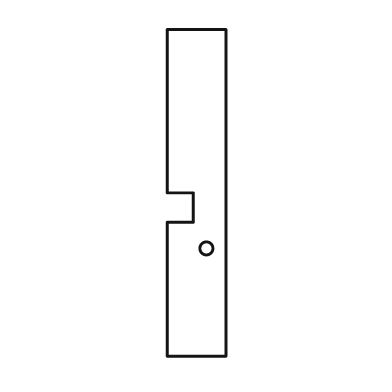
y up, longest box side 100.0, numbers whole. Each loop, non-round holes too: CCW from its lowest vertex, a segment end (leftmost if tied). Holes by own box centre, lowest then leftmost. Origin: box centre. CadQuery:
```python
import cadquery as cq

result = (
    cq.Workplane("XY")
    .moveTo(-9.0, -50.0)
    .lineTo(9.0, -50.0)
    .lineTo(9.0, 50.0)
    .lineTo(-9.0, 50.0)
    .lineTo(-9.0, 0.0)
    .lineTo(-1.0, 0.0)
    .lineTo(-1.0, -9.0)
    .lineTo(-9.0, -9.0)
    .close()
    .moveTo(3.0, -17.0)
    .circle(2.0)
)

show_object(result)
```